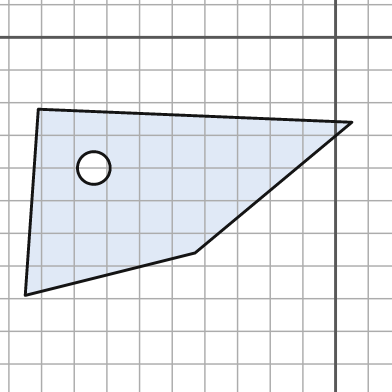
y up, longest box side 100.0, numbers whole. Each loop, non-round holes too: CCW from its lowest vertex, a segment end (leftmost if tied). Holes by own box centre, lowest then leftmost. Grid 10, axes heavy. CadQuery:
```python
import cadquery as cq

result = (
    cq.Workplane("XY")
    .moveTo(-95.0, -79.0)
    .lineTo(-43.0, -66.0)
    .lineTo(5.0, -26.0)
    .lineTo(-91.0, -22.0)
    .close()
    .moveTo(-74.0, -40.0)
    .circle(5.0)
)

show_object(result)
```